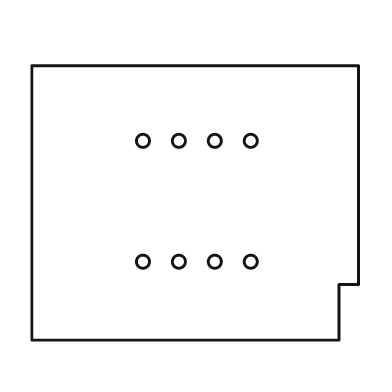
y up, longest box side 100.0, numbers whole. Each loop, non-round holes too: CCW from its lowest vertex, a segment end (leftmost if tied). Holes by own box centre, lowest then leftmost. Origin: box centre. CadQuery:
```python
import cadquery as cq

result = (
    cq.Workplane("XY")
    .moveTo(-50.0, -42.0)
    .lineTo(44.0, -42.0)
    .lineTo(44.0, -25.0)
    .lineTo(50.0, -25.0)
    .lineTo(50.0, 42.0)
    .lineTo(-50.0, 42.0)
    .close()
    .moveTo(-16.0, -18.0)
    .circle(2.0)
    .moveTo(-5.0, -18.0)
    .circle(2.0)
    .moveTo(6.0, -18.0)
    .circle(2.0)
    .moveTo(17.0, -18.0)
    .circle(2.0)
    .moveTo(-16.0, 19.0)
    .circle(2.0)
    .moveTo(-5.0, 19.0)
    .circle(2.0)
    .moveTo(6.0, 19.0)
    .circle(2.0)
    .moveTo(17.0, 19.0)
    .circle(2.0)
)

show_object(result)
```